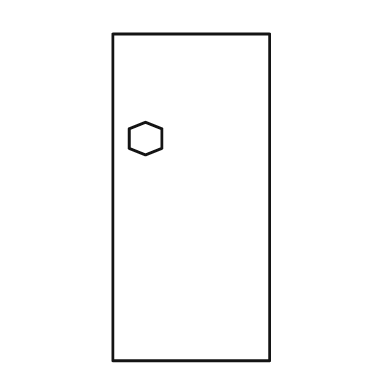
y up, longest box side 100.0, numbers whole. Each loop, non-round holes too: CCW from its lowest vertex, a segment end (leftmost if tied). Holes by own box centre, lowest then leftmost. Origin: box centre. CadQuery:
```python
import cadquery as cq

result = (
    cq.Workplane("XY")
    .moveTo(-24.0, -50.0)
    .lineTo(24.0, -50.0)
    .lineTo(24.0, 50.0)
    .lineTo(-24.0, 50.0)
    .close()
    .moveTo(-14.0, 13.0)
    .lineTo(-9.0, 15.0)
    .lineTo(-9.0, 21.0)
    .lineTo(-14.0, 23.0)
    .lineTo(-19.0, 21.0)
    .lineTo(-19.0, 15.0)
    .close()
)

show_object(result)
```